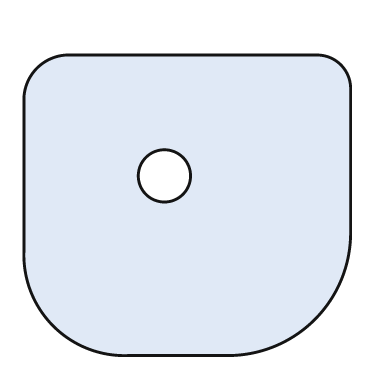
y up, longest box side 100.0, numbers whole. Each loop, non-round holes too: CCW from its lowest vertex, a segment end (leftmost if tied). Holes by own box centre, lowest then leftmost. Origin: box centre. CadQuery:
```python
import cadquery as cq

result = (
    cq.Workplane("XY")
    .moveTo(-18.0, -46.0)
    .lineTo(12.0, -46.0)
    .threePointArc((39.0, -35.0), (50.0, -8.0))
    .lineTo(50.0, 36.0)
    .threePointArc((47.0, 43.0), (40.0, 46.0))
    .lineTo(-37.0, 46.0)
    .threePointArc((-46.0, 42.0), (-50.0, 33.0))
    .lineTo(-50.0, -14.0)
    .threePointArc((-41.0, -37.0), (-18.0, -46.0))
    .close()
    .moveTo(-7.0, 9.0)
    .circle(8.0)
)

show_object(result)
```